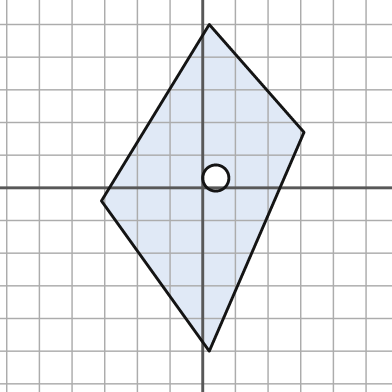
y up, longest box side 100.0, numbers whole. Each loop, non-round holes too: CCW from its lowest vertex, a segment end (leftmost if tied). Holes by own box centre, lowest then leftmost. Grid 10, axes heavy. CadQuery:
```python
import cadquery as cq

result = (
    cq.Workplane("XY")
    .moveTo(2.0, -50.0)
    .lineTo(31.0, 17.0)
    .lineTo(2.0, 50.0)
    .lineTo(-31.0, -4.0)
    .close()
    .moveTo(4.0, 3.0)
    .circle(4.0)
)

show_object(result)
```